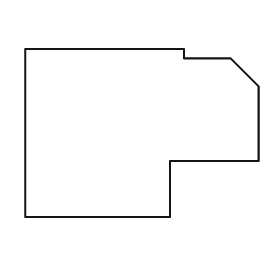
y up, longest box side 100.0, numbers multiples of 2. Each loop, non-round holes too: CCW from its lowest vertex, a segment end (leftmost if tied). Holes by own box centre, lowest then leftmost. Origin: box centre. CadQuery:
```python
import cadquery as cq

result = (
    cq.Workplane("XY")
    .moveTo(-50.0, -36.0)
    .lineTo(12.0, -36.0)
    .lineTo(12.0, -12.0)
    .lineTo(50.0, -12.0)
    .lineTo(50.0, 20.0)
    .lineTo(38.0, 32.0)
    .lineTo(18.0, 32.0)
    .lineTo(18.0, 36.0)
    .lineTo(-50.0, 36.0)
    .close()
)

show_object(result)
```